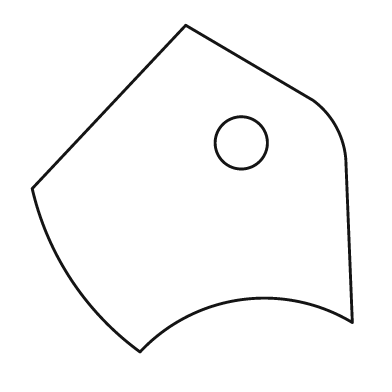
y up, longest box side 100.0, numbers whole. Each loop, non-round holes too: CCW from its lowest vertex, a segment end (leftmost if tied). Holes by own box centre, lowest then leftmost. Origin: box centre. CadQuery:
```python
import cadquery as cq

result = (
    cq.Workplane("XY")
    .moveTo(-16.0, -50.0)
    .threePointArc((15.0, -34.0), (49.0, -41.0))
    .lineTo(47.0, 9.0)
    .threePointArc((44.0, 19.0), (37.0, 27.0))
    .lineTo(-2.0, 50.0)
    .lineTo(-49.0, 0.0)
    .threePointArc((-37.0, -28.0), (-16.0, -50.0))
    .close()
    .moveTo(15.0, 14.0)
    .circle(8.0)
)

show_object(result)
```